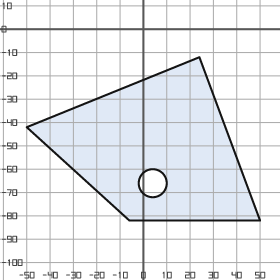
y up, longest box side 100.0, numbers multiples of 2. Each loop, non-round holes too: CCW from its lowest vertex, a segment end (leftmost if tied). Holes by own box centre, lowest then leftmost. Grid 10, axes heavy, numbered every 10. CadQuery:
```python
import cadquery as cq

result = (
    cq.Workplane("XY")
    .moveTo(-6.0, -82.0)
    .lineTo(50.0, -82.0)
    .lineTo(24.0, -12.0)
    .lineTo(-50.0, -42.0)
    .close()
    .moveTo(4.0, -66.0)
    .circle(6.0)
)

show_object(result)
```